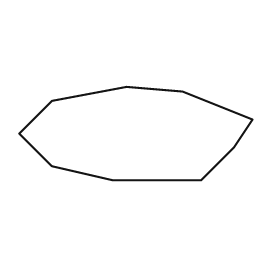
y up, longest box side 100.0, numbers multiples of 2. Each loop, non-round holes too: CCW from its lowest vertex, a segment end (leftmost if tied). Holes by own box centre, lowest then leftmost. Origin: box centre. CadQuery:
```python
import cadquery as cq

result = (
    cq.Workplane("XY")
    .moveTo(-10.0, -20.0)
    .lineTo(28.0, -20.0)
    .lineTo(42.0, -6.0)
    .lineTo(50.0, 6.0)
    .lineTo(20.0, 18.0)
    .lineTo(-4.0, 20.0)
    .lineTo(-36.0, 14.0)
    .lineTo(-50.0, 0.0)
    .lineTo(-36.0, -14.0)
    .close()
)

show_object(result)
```